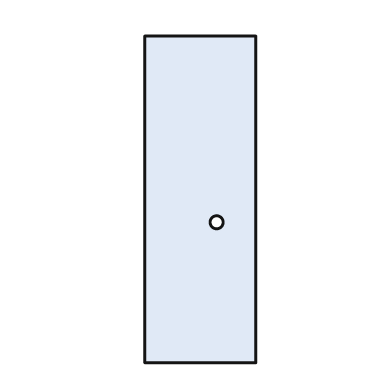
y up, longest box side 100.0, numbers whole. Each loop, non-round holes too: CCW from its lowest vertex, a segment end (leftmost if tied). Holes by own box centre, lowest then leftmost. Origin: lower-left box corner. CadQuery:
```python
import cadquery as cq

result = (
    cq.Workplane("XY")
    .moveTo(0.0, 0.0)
    .lineTo(34.0, 0.0)
    .lineTo(34.0, 100.0)
    .lineTo(0.0, 100.0)
    .close()
    .moveTo(22.0, 43.0)
    .circle(2.0)
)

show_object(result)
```